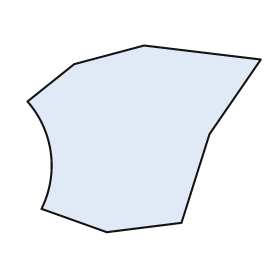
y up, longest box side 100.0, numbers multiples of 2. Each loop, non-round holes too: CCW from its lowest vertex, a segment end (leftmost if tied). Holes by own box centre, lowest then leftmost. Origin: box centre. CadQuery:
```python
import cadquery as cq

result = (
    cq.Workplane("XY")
    .moveTo(-16.0, -40.0)
    .lineTo(16.0, -36.0)
    .lineTo(28.0, 2.0)
    .lineTo(50.0, 34.0)
    .lineTo(0.0, 40.0)
    .lineTo(-30.0, 32.0)
    .lineTo(-50.0, 16.0)
    .threePointArc((-40.0, -6.0), (-44.0, -30.0))
    .close()
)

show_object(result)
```